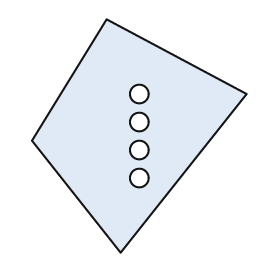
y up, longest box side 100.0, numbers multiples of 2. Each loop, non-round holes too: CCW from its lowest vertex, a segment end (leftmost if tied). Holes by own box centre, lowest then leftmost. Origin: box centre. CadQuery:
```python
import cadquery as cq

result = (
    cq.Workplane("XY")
    .moveTo(-8.0, -50.0)
    .lineTo(46.0, 18.0)
    .lineTo(-14.0, 50.0)
    .lineTo(-46.0, -2.0)
    .close()
    .moveTo(0.0, -18.0)
    .circle(4.0)
    .moveTo(0.0, -6.0)
    .circle(4.0)
    .moveTo(0.0, 6.0)
    .circle(4.0)
    .moveTo(0.0, 18.0)
    .circle(4.0)
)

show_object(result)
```